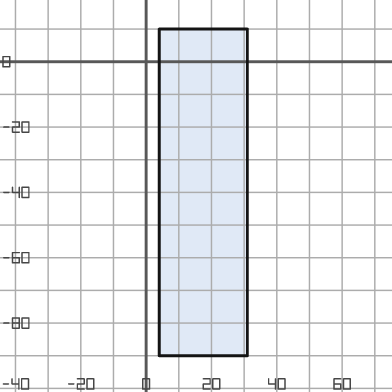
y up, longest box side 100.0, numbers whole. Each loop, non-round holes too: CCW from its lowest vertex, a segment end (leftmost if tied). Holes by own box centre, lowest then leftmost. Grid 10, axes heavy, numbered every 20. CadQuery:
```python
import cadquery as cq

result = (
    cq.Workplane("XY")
    .moveTo(4.0, -90.0)
    .lineTo(31.0, -90.0)
    .lineTo(31.0, 10.0)
    .lineTo(4.0, 10.0)
    .close()
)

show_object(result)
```